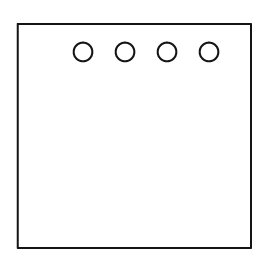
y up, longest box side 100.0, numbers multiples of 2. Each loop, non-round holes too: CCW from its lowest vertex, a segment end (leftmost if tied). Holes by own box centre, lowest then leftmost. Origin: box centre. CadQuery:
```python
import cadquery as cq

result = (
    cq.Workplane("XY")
    .moveTo(-50.0, -48.0)
    .lineTo(50.0, -48.0)
    .lineTo(50.0, 48.0)
    .lineTo(-50.0, 48.0)
    .close()
    .moveTo(-22.0, 36.0)
    .circle(4.0)
    .moveTo(-4.0, 36.0)
    .circle(4.0)
    .moveTo(14.0, 36.0)
    .circle(4.0)
    .moveTo(32.0, 36.0)
    .circle(4.0)
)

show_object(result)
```